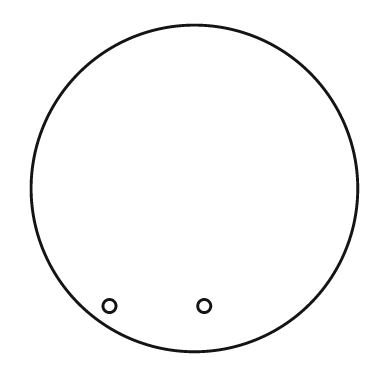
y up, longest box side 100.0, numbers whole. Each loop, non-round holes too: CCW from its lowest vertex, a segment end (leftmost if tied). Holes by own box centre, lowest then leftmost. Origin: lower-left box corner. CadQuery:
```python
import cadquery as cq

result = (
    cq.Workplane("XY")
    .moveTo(50.0, 50.0)
    .circle(50.0)
    .moveTo(24.0, 14.0)
    .circle(2.0)
    .moveTo(53.0, 14.0)
    .circle(2.0)
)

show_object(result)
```